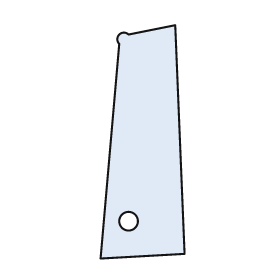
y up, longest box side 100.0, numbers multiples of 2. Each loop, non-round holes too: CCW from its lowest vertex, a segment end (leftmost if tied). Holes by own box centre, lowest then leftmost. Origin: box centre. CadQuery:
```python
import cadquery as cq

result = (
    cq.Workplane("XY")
    .moveTo(-18.0, -50.0)
    .lineTo(18.0, -48.0)
    .lineTo(14.0, 50.0)
    .lineTo(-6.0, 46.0)
    .threePointArc((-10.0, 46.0), (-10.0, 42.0))
    .close()
    .moveTo(-6.0, -34.0)
    .circle(4.0)
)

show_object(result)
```